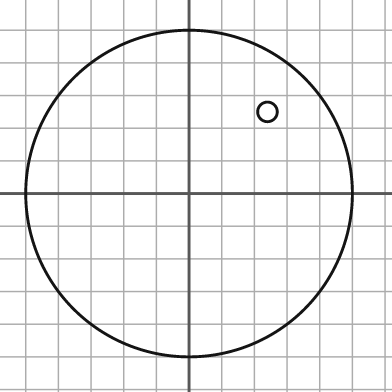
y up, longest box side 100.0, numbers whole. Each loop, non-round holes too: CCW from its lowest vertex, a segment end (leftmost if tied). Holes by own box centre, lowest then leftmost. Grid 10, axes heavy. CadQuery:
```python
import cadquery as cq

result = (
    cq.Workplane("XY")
    .moveTo(0.0, 0.0)
    .circle(50.0)
    .moveTo(24.0, 25.0)
    .circle(3.0)
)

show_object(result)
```